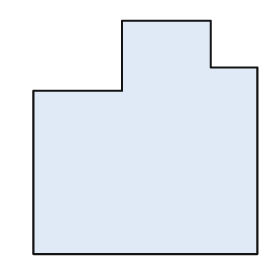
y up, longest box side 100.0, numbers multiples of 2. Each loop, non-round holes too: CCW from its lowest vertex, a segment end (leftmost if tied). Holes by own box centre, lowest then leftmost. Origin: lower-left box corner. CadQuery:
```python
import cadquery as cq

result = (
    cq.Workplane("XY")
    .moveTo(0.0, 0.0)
    .lineTo(96.0, 0.0)
    .lineTo(96.0, 80.0)
    .lineTo(76.0, 80.0)
    .lineTo(76.0, 100.0)
    .lineTo(38.0, 100.0)
    .lineTo(38.0, 70.0)
    .lineTo(0.0, 70.0)
    .close()
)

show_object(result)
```